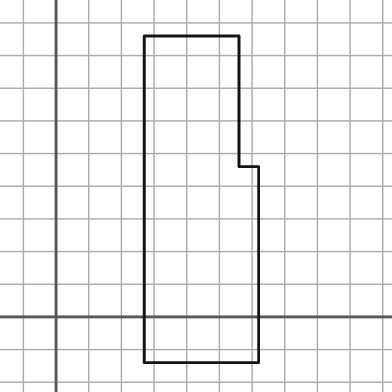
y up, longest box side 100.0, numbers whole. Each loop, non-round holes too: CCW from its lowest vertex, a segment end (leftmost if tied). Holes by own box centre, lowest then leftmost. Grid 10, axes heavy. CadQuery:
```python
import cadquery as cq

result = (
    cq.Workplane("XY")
    .moveTo(27.0, -14.0)
    .lineTo(62.0, -14.0)
    .lineTo(62.0, 46.0)
    .lineTo(56.0, 46.0)
    .lineTo(56.0, 86.0)
    .lineTo(27.0, 86.0)
    .close()
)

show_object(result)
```